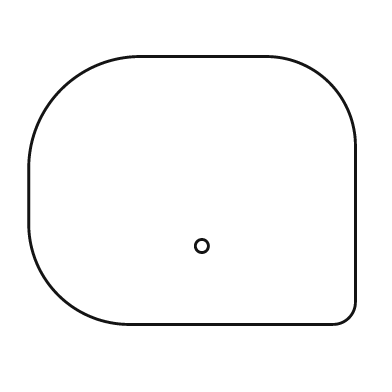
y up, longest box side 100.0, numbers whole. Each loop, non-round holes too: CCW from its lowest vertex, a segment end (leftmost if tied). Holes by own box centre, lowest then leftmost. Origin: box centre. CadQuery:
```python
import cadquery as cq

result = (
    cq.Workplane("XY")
    .moveTo(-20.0, -41.0)
    .lineTo(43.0, -41.0)
    .threePointArc((48.0, -39.0), (50.0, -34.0))
    .lineTo(50.0, 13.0)
    .threePointArc((42.0, 33.0), (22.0, 41.0))
    .lineTo(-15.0, 41.0)
    .threePointArc((-40.0, 31.0), (-50.0, 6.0))
    .lineTo(-50.0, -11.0)
    .threePointArc((-41.0, -32.0), (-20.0, -41.0))
    .close()
    .moveTo(3.0, -17.0)
    .circle(2.0)
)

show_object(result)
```